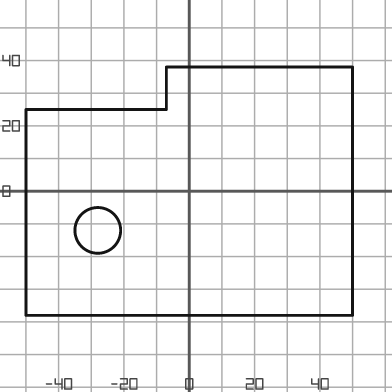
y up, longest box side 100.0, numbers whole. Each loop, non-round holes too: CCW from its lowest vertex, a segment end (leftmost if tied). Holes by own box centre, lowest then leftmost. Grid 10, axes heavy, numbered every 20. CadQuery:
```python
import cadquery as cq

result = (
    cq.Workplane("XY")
    .moveTo(-50.0, -38.0)
    .lineTo(50.0, -38.0)
    .lineTo(50.0, 38.0)
    .lineTo(-7.0, 38.0)
    .lineTo(-7.0, 25.0)
    .lineTo(-50.0, 25.0)
    .close()
    .moveTo(-28.0, -12.0)
    .circle(7.0)
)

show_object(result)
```